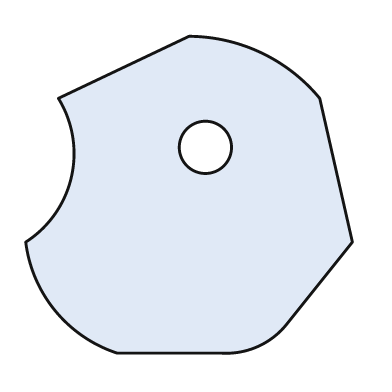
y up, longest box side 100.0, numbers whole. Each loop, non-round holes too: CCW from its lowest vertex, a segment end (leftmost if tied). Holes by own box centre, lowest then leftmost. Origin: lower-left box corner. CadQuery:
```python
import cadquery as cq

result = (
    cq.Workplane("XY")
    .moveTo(28.0, 0.0)
    .lineTo(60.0, 0.0)
    .threePointArc((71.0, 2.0), (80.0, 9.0))
    .lineTo(100.0, 34.0)
    .lineTo(90.0, 78.0)
    .threePointArc((72.0, 92.0), (50.0, 97.0))
    .lineTo(10.0, 78.0)
    .threePointArc((14.0, 54.0), (0.0, 34.0))
    .threePointArc((9.0, 13.0), (28.0, 0.0))
    .close()
    .moveTo(55.0, 63.0)
    .circle(8.0)
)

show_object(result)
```